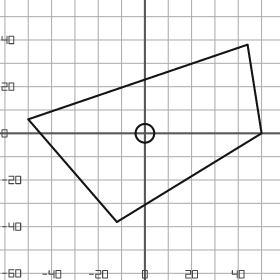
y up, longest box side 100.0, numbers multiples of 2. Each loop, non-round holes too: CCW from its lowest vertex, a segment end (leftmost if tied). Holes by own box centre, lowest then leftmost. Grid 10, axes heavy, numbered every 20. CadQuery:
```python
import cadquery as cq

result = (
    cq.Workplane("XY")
    .moveTo(-12.0, -38.0)
    .lineTo(50.0, 0.0)
    .lineTo(44.0, 38.0)
    .lineTo(-50.0, 6.0)
    .close()
    .moveTo(0.0, 0.0)
    .circle(4.0)
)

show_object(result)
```